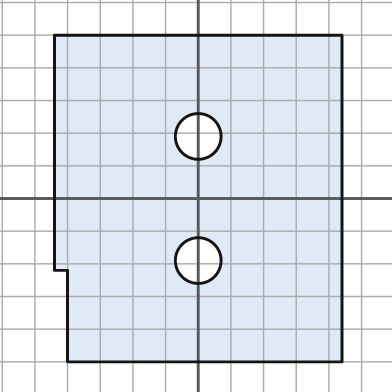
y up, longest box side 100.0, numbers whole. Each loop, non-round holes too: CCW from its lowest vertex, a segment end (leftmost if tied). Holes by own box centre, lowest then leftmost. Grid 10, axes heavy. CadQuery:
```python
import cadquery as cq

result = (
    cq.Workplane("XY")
    .moveTo(-40.0, -50.0)
    .lineTo(44.0, -50.0)
    .lineTo(44.0, 50.0)
    .lineTo(-44.0, 50.0)
    .lineTo(-44.0, -22.0)
    .lineTo(-40.0, -22.0)
    .close()
    .moveTo(0.0, -19.0)
    .circle(7.0)
    .moveTo(0.0, 19.0)
    .circle(7.0)
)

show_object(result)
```